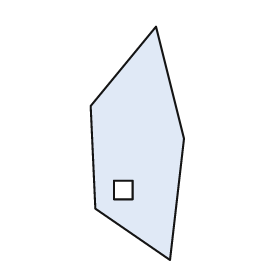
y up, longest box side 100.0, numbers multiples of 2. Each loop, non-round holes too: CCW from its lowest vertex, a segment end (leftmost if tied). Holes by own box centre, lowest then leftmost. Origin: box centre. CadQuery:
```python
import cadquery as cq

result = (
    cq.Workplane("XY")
    .moveTo(14.0, -50.0)
    .lineTo(20.0, 2.0)
    .lineTo(8.0, 50.0)
    .lineTo(-20.0, 16.0)
    .lineTo(-18.0, -28.0)
    .close()
    .moveTo(-10.0, -24.0)
    .lineTo(-2.0, -24.0)
    .lineTo(-2.0, -16.0)
    .lineTo(-10.0, -16.0)
    .close()
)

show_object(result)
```